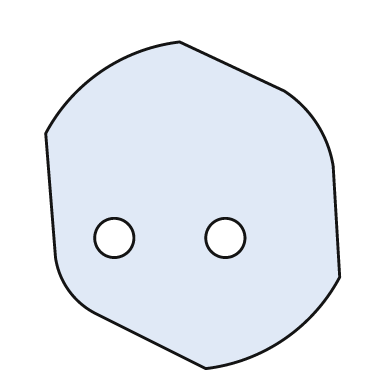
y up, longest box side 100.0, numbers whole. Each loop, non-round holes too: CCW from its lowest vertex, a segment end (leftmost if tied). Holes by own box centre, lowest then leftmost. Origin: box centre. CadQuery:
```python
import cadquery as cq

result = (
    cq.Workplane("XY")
    .moveTo(4.0, -50.0)
    .threePointArc((28.0, -41.0), (45.0, -22.0))
    .lineTo(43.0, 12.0)
    .threePointArc((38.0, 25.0), (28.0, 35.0))
    .lineTo(-4.0, 50.0)
    .threePointArc((-28.0, 41.0), (-45.0, 22.0))
    .lineTo(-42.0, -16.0)
    .threePointArc((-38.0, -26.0), (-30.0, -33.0))
    .close()
    .moveTo(-24.0, -10.0)
    .circle(6.0)
    .moveTo(10.0, -10.0)
    .circle(6.0)
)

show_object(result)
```